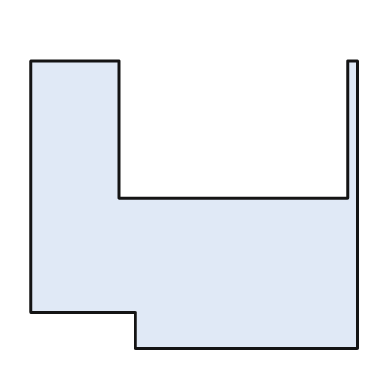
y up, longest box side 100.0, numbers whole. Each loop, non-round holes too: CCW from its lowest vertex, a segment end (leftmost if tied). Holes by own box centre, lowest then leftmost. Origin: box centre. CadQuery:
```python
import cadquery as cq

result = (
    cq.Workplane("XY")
    .moveTo(-18.0, -44.0)
    .lineTo(50.0, -44.0)
    .lineTo(50.0, 44.0)
    .lineTo(47.0, 44.0)
    .lineTo(47.0, 2.0)
    .lineTo(-23.0, 2.0)
    .lineTo(-23.0, 44.0)
    .lineTo(-50.0, 44.0)
    .lineTo(-50.0, -33.0)
    .lineTo(-18.0, -33.0)
    .close()
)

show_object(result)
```